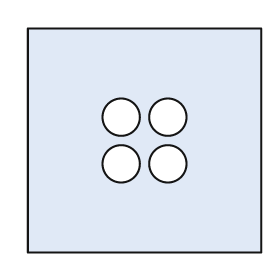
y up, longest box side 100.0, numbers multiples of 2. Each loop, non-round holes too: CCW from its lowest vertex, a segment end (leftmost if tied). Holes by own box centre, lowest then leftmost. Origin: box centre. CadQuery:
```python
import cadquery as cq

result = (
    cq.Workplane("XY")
    .moveTo(-50.0, -48.0)
    .lineTo(50.0, -48.0)
    .lineTo(50.0, 48.0)
    .lineTo(-50.0, 48.0)
    .close()
    .moveTo(-10.0, -10.0)
    .circle(8.0)
    .moveTo(10.0, -10.0)
    .circle(8.0)
    .moveTo(-10.0, 10.0)
    .circle(8.0)
    .moveTo(10.0, 10.0)
    .circle(8.0)
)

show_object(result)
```